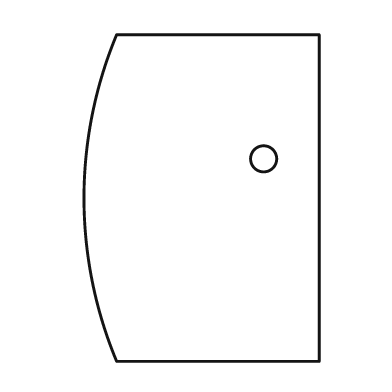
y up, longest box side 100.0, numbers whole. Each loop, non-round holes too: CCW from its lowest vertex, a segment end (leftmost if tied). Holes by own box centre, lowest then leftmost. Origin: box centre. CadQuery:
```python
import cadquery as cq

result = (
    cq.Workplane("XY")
    .moveTo(-26.0, -50.0)
    .lineTo(36.0, -50.0)
    .lineTo(36.0, 50.0)
    .lineTo(-26.0, 50.0)
    .threePointArc((-36.0, 0.0), (-26.0, -50.0))
    .close()
    .moveTo(19.0, 12.0)
    .circle(4.0)
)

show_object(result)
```